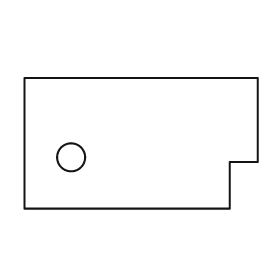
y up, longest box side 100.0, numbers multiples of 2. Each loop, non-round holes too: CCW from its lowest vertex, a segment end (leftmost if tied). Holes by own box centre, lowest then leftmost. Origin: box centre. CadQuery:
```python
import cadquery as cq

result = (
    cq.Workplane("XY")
    .moveTo(-50.0, -28.0)
    .lineTo(38.0, -28.0)
    .lineTo(38.0, -8.0)
    .lineTo(50.0, -8.0)
    .lineTo(50.0, 28.0)
    .lineTo(-50.0, 28.0)
    .close()
    .moveTo(-30.0, -6.0)
    .circle(6.0)
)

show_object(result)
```